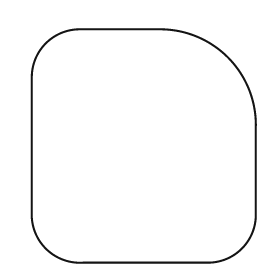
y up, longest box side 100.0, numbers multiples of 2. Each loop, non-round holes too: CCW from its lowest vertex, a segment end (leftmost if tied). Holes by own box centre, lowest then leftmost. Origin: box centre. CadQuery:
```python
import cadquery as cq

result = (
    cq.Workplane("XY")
    .moveTo(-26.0, -50.0)
    .lineTo(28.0, -50.0)
    .threePointArc((42.0, -44.0), (48.0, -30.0))
    .lineTo(48.0, 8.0)
    .threePointArc((36.0, 38.0), (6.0, 50.0))
    .lineTo(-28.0, 50.0)
    .threePointArc((-42.0, 44.0), (-48.0, 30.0))
    .lineTo(-48.0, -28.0)
    .threePointArc((-42.0, -44.0), (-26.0, -50.0))
    .close()
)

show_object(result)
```